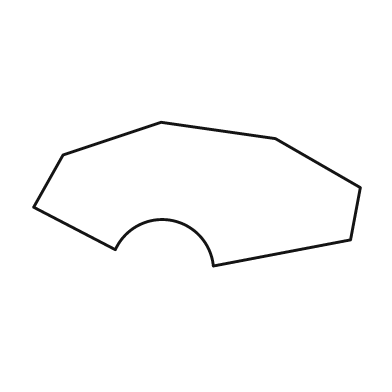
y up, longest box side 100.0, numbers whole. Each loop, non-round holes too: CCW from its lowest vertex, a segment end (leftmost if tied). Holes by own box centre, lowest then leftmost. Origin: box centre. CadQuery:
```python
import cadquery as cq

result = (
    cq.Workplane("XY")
    .moveTo(5.0, -22.0)
    .lineTo(47.0, -14.0)
    .lineTo(50.0, 2.0)
    .lineTo(24.0, 17.0)
    .lineTo(-11.0, 22.0)
    .lineTo(-41.0, 12.0)
    .lineTo(-50.0, -4.0)
    .lineTo(-25.0, -17.0)
    .threePointArc((-8.0, -8.0), (5.0, -22.0))
    .close()
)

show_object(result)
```